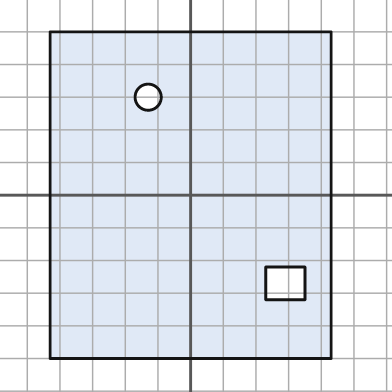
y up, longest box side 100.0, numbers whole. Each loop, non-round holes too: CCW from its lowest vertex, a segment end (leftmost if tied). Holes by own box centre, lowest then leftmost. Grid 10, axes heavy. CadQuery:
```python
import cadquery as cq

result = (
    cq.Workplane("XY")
    .moveTo(-43.0, -50.0)
    .lineTo(43.0, -50.0)
    .lineTo(43.0, 50.0)
    .lineTo(-43.0, 50.0)
    .close()
    .moveTo(23.0, -32.0)
    .lineTo(35.0, -32.0)
    .lineTo(35.0, -22.0)
    .lineTo(23.0, -22.0)
    .close()
    .moveTo(-13.0, 30.0)
    .circle(4.0)
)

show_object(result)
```